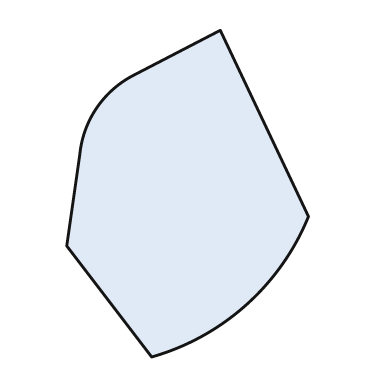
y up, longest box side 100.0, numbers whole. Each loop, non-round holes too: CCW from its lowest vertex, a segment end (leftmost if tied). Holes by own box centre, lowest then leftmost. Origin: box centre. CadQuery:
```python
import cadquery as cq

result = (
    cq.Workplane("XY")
    .moveTo(-11.0, -50.0)
    .threePointArc((18.0, -34.0), (37.0, -7.0))
    .lineTo(10.0, 50.0)
    .lineTo(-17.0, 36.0)
    .threePointArc((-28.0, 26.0), (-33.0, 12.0))
    .lineTo(-37.0, -16.0)
    .close()
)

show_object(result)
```